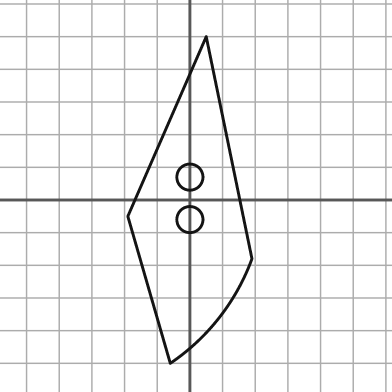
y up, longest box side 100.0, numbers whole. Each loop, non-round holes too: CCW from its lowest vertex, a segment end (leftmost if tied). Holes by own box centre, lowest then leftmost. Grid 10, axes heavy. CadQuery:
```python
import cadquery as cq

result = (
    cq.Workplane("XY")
    .moveTo(-6.0, -50.0)
    .threePointArc((9.0, -36.0), (19.0, -18.0))
    .lineTo(5.0, 50.0)
    .lineTo(-19.0, -5.0)
    .close()
    .moveTo(0.0, -6.0)
    .circle(4.0)
    .moveTo(0.0, 7.0)
    .circle(4.0)
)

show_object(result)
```